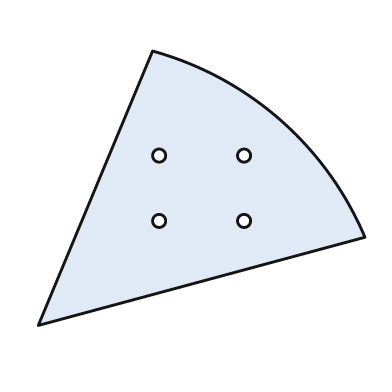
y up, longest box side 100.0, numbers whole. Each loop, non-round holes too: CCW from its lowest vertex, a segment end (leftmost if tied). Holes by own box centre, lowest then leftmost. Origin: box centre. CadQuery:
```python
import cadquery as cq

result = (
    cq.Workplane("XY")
    .moveTo(-50.0, -42.0)
    .lineTo(50.0, -15.0)
    .threePointArc((24.0, 21.0), (-15.0, 42.0))
    .close()
    .moveTo(-13.0, -10.0)
    .circle(2.0)
    .moveTo(13.0, -10.0)
    .circle(2.0)
    .moveTo(-13.0, 10.0)
    .circle(2.0)
    .moveTo(13.0, 10.0)
    .circle(2.0)
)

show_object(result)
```